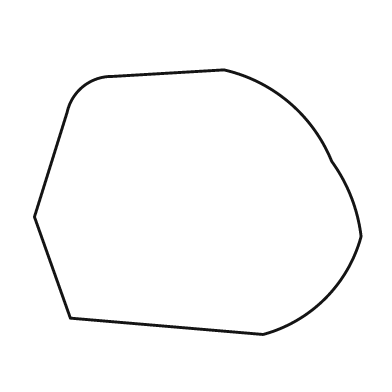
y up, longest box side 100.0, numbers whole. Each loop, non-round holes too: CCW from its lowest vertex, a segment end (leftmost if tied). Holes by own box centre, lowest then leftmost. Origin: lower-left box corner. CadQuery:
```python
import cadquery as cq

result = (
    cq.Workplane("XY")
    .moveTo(70.0, 0.0)
    .threePointArc((89.0, 11.0), (100.0, 30.0))
    .threePointArc((97.0, 42.0), (91.0, 53.0))
    .threePointArc((78.0, 71.0), (58.0, 81.0))
    .lineTo(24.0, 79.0)
    .threePointArc((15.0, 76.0), (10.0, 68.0))
    .lineTo(0.0, 36.0)
    .lineTo(11.0, 5.0)
    .close()
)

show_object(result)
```